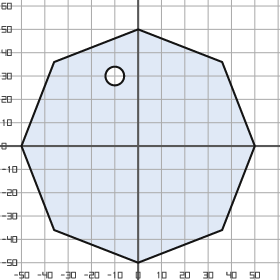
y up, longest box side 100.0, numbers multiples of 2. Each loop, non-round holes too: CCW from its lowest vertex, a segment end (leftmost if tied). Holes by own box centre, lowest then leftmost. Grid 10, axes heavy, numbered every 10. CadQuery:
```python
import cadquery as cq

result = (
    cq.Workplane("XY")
    .moveTo(0.0, -50.0)
    .lineTo(36.0, -36.0)
    .lineTo(50.0, 0.0)
    .lineTo(36.0, 36.0)
    .lineTo(0.0, 50.0)
    .lineTo(-36.0, 36.0)
    .lineTo(-50.0, 0.0)
    .lineTo(-36.0, -36.0)
    .close()
    .moveTo(-10.0, 30.0)
    .circle(4.0)
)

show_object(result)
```